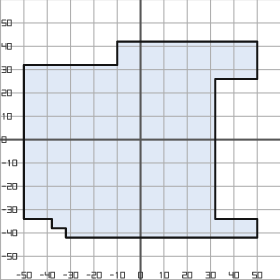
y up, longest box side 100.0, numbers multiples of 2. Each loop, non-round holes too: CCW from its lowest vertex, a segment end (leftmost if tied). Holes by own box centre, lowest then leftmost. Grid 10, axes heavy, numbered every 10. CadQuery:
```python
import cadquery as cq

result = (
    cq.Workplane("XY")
    .moveTo(-32.0, -42.0)
    .lineTo(50.0, -42.0)
    .lineTo(50.0, -34.0)
    .lineTo(32.0, -34.0)
    .lineTo(32.0, 26.0)
    .lineTo(50.0, 26.0)
    .lineTo(50.0, 42.0)
    .lineTo(-10.0, 42.0)
    .lineTo(-10.0, 32.0)
    .lineTo(-50.0, 32.0)
    .lineTo(-50.0, -34.0)
    .lineTo(-38.0, -34.0)
    .lineTo(-38.0, -38.0)
    .lineTo(-32.0, -38.0)
    .close()
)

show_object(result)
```